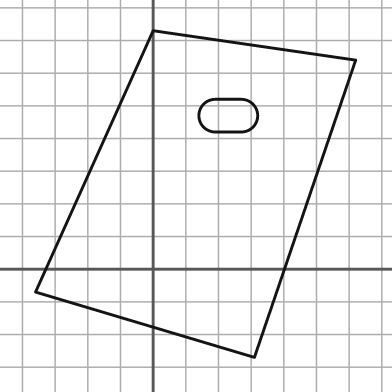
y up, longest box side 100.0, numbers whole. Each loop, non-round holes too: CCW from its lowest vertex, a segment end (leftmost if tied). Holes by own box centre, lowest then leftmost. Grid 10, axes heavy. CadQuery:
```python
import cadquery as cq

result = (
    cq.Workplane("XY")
    .moveTo(31.0, -27.0)
    .lineTo(62.0, 64.0)
    .lineTo(0.0, 73.0)
    .lineTo(-36.0, -7.0)
    .close()
    .moveTo(19.0, 42.0)
    .lineTo(27.0, 42.0)
    .threePointArc((32.0, 47.0), (27.0, 52.0))
    .lineTo(19.0, 52.0)
    .threePointArc((14.0, 47.0), (19.0, 42.0))
    .close()
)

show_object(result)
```